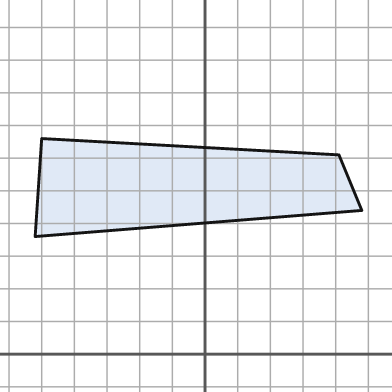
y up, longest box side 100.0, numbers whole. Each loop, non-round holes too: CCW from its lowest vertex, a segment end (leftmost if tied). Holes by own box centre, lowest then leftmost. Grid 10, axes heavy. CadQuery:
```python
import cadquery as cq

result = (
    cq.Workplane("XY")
    .moveTo(-52.0, 36.0)
    .lineTo(48.0, 44.0)
    .lineTo(41.0, 61.0)
    .lineTo(-50.0, 66.0)
    .close()
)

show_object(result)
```